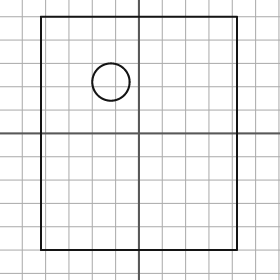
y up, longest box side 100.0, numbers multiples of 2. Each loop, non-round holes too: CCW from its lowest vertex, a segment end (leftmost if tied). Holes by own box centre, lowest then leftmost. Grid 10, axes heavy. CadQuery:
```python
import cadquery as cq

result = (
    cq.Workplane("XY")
    .moveTo(-42.0, -50.0)
    .lineTo(42.0, -50.0)
    .lineTo(42.0, 50.0)
    .lineTo(-42.0, 50.0)
    .close()
    .moveTo(-12.0, 22.0)
    .circle(8.0)
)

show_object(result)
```